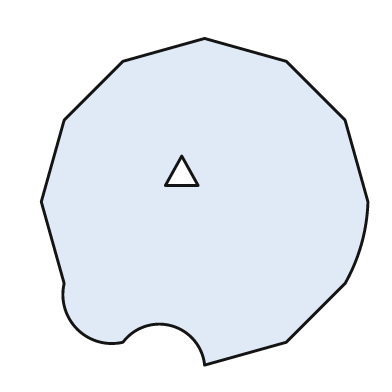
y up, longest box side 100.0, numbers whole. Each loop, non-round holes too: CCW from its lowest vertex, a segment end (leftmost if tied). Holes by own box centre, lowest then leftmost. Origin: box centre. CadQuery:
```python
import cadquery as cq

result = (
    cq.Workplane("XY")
    .moveTo(0.0, -50.0)
    .lineTo(25.0, -43.0)
    .lineTo(43.0, -25.0)
    .threePointArc((48.0, -13.0), (50.0, 0.0))
    .lineTo(43.0, 25.0)
    .lineTo(25.0, 43.0)
    .lineTo(0.0, 50.0)
    .lineTo(-25.0, 43.0)
    .lineTo(-43.0, 25.0)
    .lineTo(-50.0, 0.0)
    .lineTo(-43.0, -25.0)
    .threePointArc((-39.0, -39.0), (-25.0, -43.0))
    .threePointArc((-10.0, -38.0), (0.0, -50.0))
    .close()
    .moveTo(-12.0, 5.0)
    .lineTo(-2.0, 5.0)
    .lineTo(-7.0, 14.0)
    .close()
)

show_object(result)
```